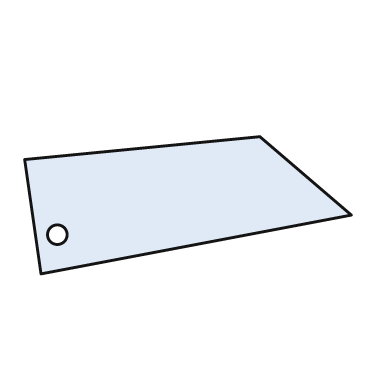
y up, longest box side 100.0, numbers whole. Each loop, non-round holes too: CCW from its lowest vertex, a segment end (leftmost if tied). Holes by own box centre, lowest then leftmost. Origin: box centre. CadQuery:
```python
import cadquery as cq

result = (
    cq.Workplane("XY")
    .moveTo(-45.0, -21.0)
    .lineTo(50.0, -3.0)
    .lineTo(22.0, 21.0)
    .lineTo(-50.0, 14.0)
    .close()
    .moveTo(-40.0, -9.0)
    .circle(3.0)
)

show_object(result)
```